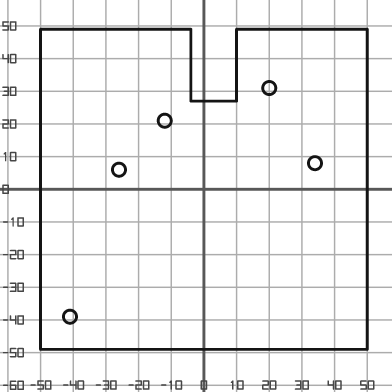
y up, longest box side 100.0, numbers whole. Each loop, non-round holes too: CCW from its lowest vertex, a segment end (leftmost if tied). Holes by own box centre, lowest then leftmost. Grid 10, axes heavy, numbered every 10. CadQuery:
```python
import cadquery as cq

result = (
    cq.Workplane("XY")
    .moveTo(-50.0, -49.0)
    .lineTo(50.0, -49.0)
    .lineTo(50.0, 49.0)
    .lineTo(10.0, 49.0)
    .lineTo(10.0, 27.0)
    .lineTo(-4.0, 27.0)
    .lineTo(-4.0, 49.0)
    .lineTo(-50.0, 49.0)
    .close()
    .moveTo(-41.0, -39.0)
    .circle(2.0)
    .moveTo(-26.0, 6.0)
    .circle(2.0)
    .moveTo(34.0, 8.0)
    .circle(2.0)
    .moveTo(-12.0, 21.0)
    .circle(2.0)
    .moveTo(20.0, 31.0)
    .circle(2.0)
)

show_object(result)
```